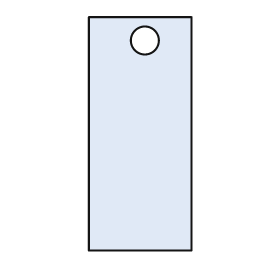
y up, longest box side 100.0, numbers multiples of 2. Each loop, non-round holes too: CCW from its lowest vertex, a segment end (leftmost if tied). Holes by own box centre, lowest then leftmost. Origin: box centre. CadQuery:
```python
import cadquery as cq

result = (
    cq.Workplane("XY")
    .moveTo(-22.0, -50.0)
    .lineTo(22.0, -50.0)
    .lineTo(22.0, 50.0)
    .lineTo(-22.0, 50.0)
    .close()
    .moveTo(2.0, 40.0)
    .circle(6.0)
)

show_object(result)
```